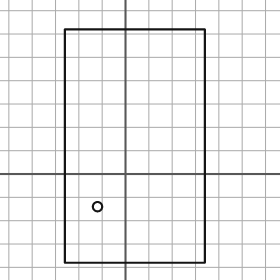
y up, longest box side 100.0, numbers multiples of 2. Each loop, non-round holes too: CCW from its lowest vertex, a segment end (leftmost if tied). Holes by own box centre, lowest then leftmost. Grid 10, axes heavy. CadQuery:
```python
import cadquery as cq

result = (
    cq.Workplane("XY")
    .moveTo(-26.0, -38.0)
    .lineTo(34.0, -38.0)
    .lineTo(34.0, 62.0)
    .lineTo(-26.0, 62.0)
    .close()
    .moveTo(-12.0, -14.0)
    .circle(2.0)
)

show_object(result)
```